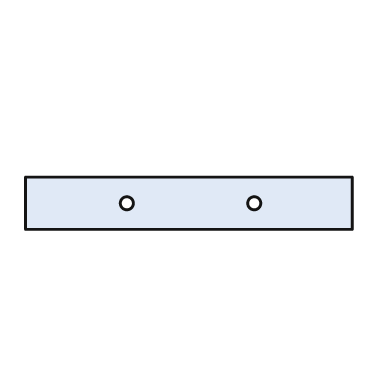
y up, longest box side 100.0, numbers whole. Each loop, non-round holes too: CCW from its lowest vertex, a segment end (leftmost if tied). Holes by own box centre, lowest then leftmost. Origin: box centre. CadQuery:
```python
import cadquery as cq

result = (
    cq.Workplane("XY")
    .moveTo(-50.0, -8.0)
    .lineTo(50.0, -8.0)
    .lineTo(50.0, 8.0)
    .lineTo(-50.0, 8.0)
    .close()
    .moveTo(-19.0, 0.0)
    .circle(2.0)
    .moveTo(20.0, 0.0)
    .circle(2.0)
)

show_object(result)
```